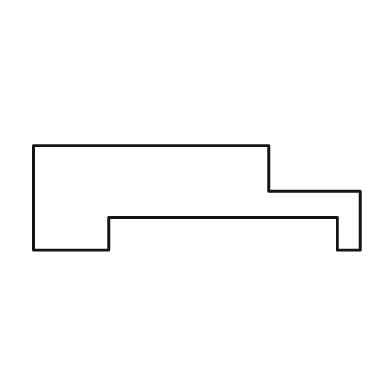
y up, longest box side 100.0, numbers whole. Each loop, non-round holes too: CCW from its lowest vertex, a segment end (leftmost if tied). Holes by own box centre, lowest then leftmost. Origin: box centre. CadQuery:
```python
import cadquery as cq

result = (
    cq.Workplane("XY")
    .moveTo(-50.0, -16.0)
    .lineTo(-27.0, -16.0)
    .lineTo(-27.0, -6.0)
    .lineTo(43.0, -6.0)
    .lineTo(43.0, -16.0)
    .lineTo(50.0, -16.0)
    .lineTo(50.0, 2.0)
    .lineTo(22.0, 2.0)
    .lineTo(22.0, 16.0)
    .lineTo(-50.0, 16.0)
    .close()
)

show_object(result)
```